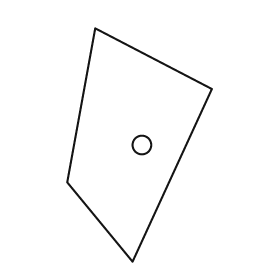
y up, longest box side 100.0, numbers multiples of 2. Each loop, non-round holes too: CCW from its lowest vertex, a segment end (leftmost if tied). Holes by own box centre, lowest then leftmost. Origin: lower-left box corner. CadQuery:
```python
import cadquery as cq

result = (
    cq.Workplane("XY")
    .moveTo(28.0, 0.0)
    .lineTo(62.0, 74.0)
    .lineTo(12.0, 100.0)
    .lineTo(0.0, 34.0)
    .close()
    .moveTo(32.0, 50.0)
    .circle(4.0)
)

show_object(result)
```